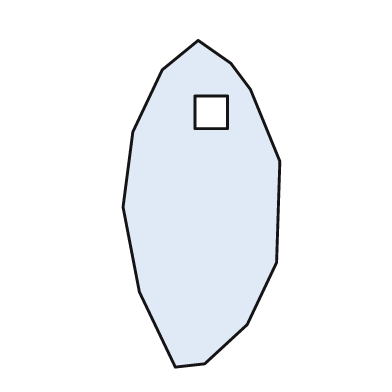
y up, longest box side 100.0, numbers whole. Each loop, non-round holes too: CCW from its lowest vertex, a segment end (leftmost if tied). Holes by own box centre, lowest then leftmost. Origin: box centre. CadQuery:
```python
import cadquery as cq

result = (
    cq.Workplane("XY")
    .moveTo(-8.0, -50.0)
    .lineTo(1.0, -49.0)
    .lineTo(14.0, -37.0)
    .lineTo(23.0, -18.0)
    .lineTo(24.0, 13.0)
    .lineTo(15.0, 35.0)
    .lineTo(9.0, 43.0)
    .lineTo(-1.0, 50.0)
    .lineTo(-12.0, 41.0)
    .lineTo(-21.0, 22.0)
    .lineTo(-24.0, -1.0)
    .lineTo(-19.0, -27.0)
    .close()
    .moveTo(-2.0, 23.0)
    .lineTo(8.0, 23.0)
    .lineTo(8.0, 33.0)
    .lineTo(-2.0, 33.0)
    .close()
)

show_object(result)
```